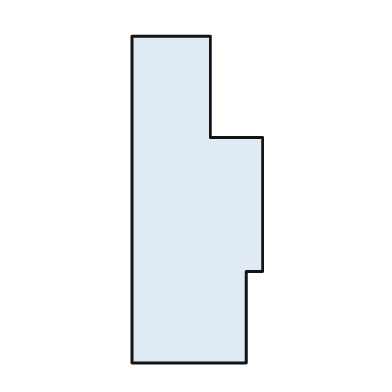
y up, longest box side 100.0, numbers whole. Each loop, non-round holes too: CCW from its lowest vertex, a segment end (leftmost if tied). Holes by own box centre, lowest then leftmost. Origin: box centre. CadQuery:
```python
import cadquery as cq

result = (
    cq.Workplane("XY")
    .moveTo(-20.0, -50.0)
    .lineTo(15.0, -50.0)
    .lineTo(15.0, -22.0)
    .lineTo(20.0, -22.0)
    .lineTo(20.0, 19.0)
    .lineTo(4.0, 19.0)
    .lineTo(4.0, 50.0)
    .lineTo(-20.0, 50.0)
    .close()
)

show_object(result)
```